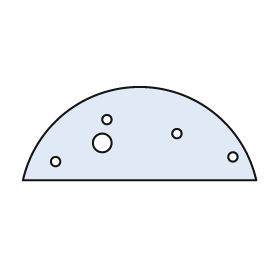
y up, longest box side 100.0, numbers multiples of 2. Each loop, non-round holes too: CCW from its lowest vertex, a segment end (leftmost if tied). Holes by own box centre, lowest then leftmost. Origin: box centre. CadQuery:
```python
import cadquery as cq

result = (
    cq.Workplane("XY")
    .moveTo(-50.0, -20.0)
    .lineTo(50.0, -20.0)
    .threePointArc((0.0, 20.0), (-50.0, -20.0))
    .close()
    .moveTo(-36.0, -12.0)
    .circle(2.0)
    .moveTo(40.0, -10.0)
    .circle(2.0)
    .moveTo(-16.0, -4.0)
    .circle(4.0)
    .moveTo(16.0, 0.0)
    .circle(2.0)
    .moveTo(-14.0, 6.0)
    .circle(2.0)
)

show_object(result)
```